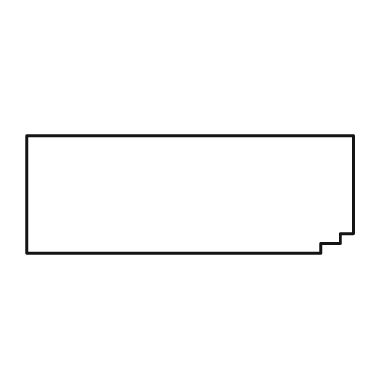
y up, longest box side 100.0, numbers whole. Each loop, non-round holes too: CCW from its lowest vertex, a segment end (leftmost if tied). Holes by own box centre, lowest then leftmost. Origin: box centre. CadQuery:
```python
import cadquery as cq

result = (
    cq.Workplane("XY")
    .moveTo(-50.0, -18.0)
    .lineTo(40.0, -18.0)
    .lineTo(40.0, -15.0)
    .lineTo(46.0, -15.0)
    .lineTo(46.0, -12.0)
    .lineTo(50.0, -12.0)
    .lineTo(50.0, 18.0)
    .lineTo(-50.0, 18.0)
    .close()
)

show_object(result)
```